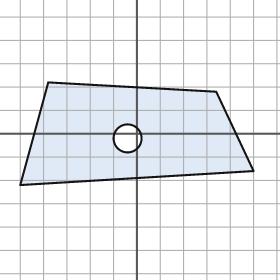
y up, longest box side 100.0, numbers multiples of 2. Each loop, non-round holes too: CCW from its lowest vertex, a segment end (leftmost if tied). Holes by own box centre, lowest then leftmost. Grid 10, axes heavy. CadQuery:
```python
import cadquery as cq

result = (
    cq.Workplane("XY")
    .moveTo(-50.0, -22.0)
    .lineTo(50.0, -16.0)
    .lineTo(34.0, 18.0)
    .lineTo(-38.0, 22.0)
    .close()
    .moveTo(-4.0, -2.0)
    .circle(6.0)
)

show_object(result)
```